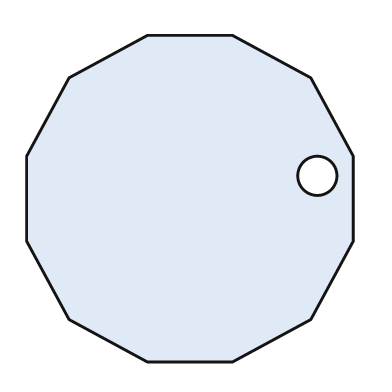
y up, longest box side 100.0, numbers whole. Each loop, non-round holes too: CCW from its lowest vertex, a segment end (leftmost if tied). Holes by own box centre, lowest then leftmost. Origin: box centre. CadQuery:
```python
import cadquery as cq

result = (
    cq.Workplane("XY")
    .moveTo(-13.0, -50.0)
    .lineTo(13.0, -50.0)
    .lineTo(37.0, -37.0)
    .lineTo(50.0, -13.0)
    .lineTo(50.0, 13.0)
    .lineTo(37.0, 37.0)
    .lineTo(13.0, 50.0)
    .lineTo(-13.0, 50.0)
    .lineTo(-37.0, 37.0)
    .lineTo(-50.0, 13.0)
    .lineTo(-50.0, -13.0)
    .lineTo(-37.0, -37.0)
    .close()
    .moveTo(39.0, 7.0)
    .circle(6.0)
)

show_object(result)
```